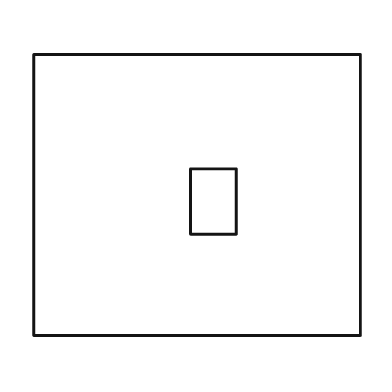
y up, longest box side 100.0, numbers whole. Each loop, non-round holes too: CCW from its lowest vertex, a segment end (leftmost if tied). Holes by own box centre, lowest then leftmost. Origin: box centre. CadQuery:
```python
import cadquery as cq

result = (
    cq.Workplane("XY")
    .moveTo(-50.0, -43.0)
    .lineTo(50.0, -43.0)
    .lineTo(50.0, 43.0)
    .lineTo(-50.0, 43.0)
    .close()
    .moveTo(-2.0, -12.0)
    .lineTo(12.0, -12.0)
    .lineTo(12.0, 8.0)
    .lineTo(-2.0, 8.0)
    .close()
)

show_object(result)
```